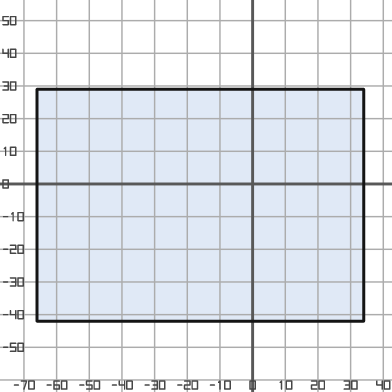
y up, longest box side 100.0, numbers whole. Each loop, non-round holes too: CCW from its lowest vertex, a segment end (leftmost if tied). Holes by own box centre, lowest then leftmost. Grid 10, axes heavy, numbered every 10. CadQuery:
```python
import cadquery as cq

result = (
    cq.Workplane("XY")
    .moveTo(-66.0, -42.0)
    .lineTo(34.0, -42.0)
    .lineTo(34.0, 29.0)
    .lineTo(-66.0, 29.0)
    .close()
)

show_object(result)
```